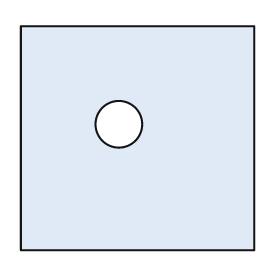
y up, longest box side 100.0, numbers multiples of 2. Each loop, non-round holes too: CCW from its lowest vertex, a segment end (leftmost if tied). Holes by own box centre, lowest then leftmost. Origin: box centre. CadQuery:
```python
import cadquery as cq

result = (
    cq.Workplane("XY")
    .moveTo(-50.0, -48.0)
    .lineTo(50.0, -48.0)
    .lineTo(50.0, 48.0)
    .lineTo(-50.0, 48.0)
    .close()
    .moveTo(-8.0, 6.0)
    .circle(10.0)
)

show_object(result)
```